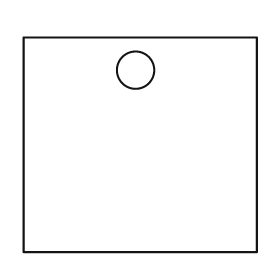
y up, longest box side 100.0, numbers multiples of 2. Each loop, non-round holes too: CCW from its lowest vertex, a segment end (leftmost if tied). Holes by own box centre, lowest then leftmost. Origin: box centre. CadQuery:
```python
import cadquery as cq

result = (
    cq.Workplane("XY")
    .moveTo(-50.0, -46.0)
    .lineTo(50.0, -46.0)
    .lineTo(50.0, 46.0)
    .lineTo(-50.0, 46.0)
    .close()
    .moveTo(-2.0, 32.0)
    .circle(8.0)
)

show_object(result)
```